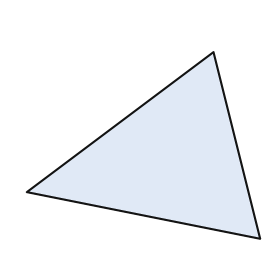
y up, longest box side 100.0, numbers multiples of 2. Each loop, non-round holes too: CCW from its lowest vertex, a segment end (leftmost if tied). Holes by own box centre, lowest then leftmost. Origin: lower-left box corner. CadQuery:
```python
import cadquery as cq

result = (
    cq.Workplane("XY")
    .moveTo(100.0, 0.0)
    .lineTo(80.0, 80.0)
    .lineTo(0.0, 20.0)
    .close()
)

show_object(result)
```